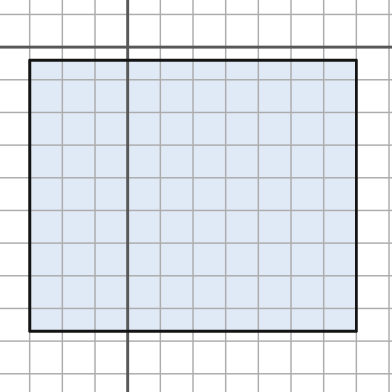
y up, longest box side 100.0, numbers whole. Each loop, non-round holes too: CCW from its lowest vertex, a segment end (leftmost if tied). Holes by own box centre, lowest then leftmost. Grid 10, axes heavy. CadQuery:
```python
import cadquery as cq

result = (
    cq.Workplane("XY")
    .moveTo(-30.0, -87.0)
    .lineTo(70.0, -87.0)
    .lineTo(70.0, -4.0)
    .lineTo(-30.0, -4.0)
    .close()
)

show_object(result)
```